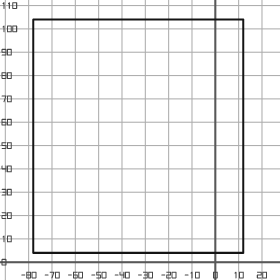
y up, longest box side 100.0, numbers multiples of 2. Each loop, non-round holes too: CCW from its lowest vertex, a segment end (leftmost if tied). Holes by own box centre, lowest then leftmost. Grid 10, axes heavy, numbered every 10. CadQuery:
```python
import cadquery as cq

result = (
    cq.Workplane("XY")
    .moveTo(-78.0, 4.0)
    .lineTo(12.0, 4.0)
    .lineTo(12.0, 104.0)
    .lineTo(-78.0, 104.0)
    .close()
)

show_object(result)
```